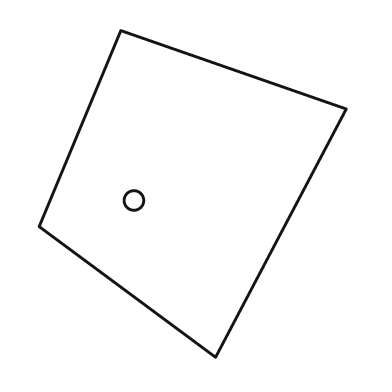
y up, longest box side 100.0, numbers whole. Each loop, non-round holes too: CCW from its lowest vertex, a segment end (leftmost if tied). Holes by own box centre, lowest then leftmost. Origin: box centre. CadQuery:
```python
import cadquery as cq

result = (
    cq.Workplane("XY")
    .moveTo(7.0, -50.0)
    .lineTo(47.0, 26.0)
    .lineTo(-22.0, 50.0)
    .lineTo(-47.0, -10.0)
    .close()
    .moveTo(-18.0, -2.0)
    .circle(3.0)
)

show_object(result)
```